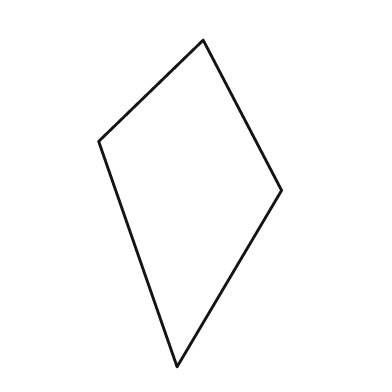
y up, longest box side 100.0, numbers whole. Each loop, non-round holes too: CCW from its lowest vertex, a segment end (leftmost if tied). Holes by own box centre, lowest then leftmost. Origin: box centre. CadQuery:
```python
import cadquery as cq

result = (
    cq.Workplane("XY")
    .moveTo(-4.0, -50.0)
    .lineTo(28.0, 4.0)
    .lineTo(4.0, 50.0)
    .lineTo(-28.0, 19.0)
    .close()
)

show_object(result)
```